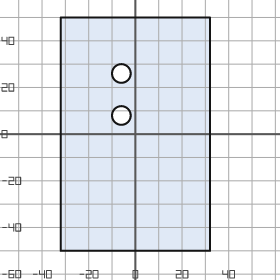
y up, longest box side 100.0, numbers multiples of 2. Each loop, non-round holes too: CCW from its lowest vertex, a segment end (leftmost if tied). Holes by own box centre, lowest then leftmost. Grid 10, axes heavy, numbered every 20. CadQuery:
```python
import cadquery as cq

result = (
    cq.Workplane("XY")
    .moveTo(-32.0, -50.0)
    .lineTo(32.0, -50.0)
    .lineTo(32.0, 50.0)
    .lineTo(-32.0, 50.0)
    .close()
    .moveTo(-6.0, 8.0)
    .circle(4.0)
    .moveTo(-6.0, 26.0)
    .circle(4.0)
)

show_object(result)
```